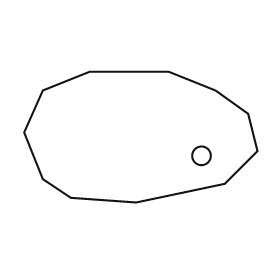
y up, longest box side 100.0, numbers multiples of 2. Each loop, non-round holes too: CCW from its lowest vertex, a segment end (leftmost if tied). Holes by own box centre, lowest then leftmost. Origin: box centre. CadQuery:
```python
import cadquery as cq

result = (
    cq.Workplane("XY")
    .moveTo(-2.0, -28.0)
    .lineTo(36.0, -20.0)
    .lineTo(50.0, -6.0)
    .lineTo(46.0, 10.0)
    .lineTo(32.0, 20.0)
    .lineTo(12.0, 28.0)
    .lineTo(-22.0, 28.0)
    .lineTo(-42.0, 20.0)
    .lineTo(-50.0, 2.0)
    .lineTo(-42.0, -18.0)
    .lineTo(-30.0, -26.0)
    .close()
    .moveTo(26.0, -8.0)
    .circle(4.0)
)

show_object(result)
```